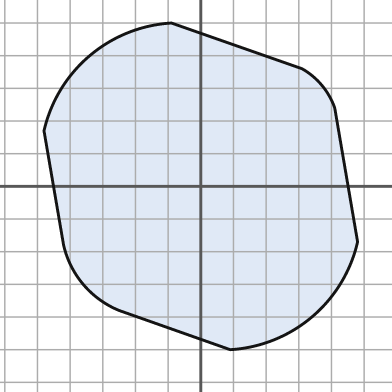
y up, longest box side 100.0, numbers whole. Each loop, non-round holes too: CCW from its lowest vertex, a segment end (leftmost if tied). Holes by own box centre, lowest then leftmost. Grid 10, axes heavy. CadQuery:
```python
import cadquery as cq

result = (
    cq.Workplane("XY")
    .moveTo(9.0, -50.0)
    .threePointArc((34.0, -40.0), (48.0, -17.0))
    .lineTo(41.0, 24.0)
    .threePointArc((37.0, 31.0), (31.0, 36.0))
    .lineTo(-9.0, 50.0)
    .threePointArc((-34.0, 40.0), (-48.0, 17.0))
    .lineTo(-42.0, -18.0)
    .threePointArc((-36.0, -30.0), (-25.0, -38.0))
    .close()
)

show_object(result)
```